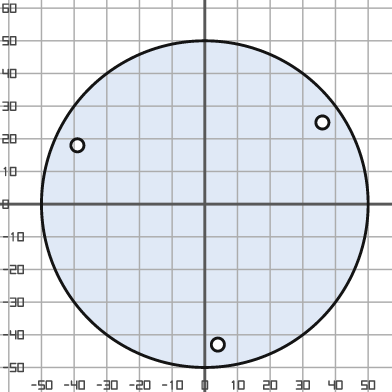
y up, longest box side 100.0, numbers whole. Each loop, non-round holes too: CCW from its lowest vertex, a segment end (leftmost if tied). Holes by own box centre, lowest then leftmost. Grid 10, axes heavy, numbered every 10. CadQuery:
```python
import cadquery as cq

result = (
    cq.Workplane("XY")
    .moveTo(0.0, 0.0)
    .circle(50.0)
    .moveTo(4.0, -43.0)
    .circle(2.0)
    .moveTo(-39.0, 18.0)
    .circle(2.0)
    .moveTo(36.0, 25.0)
    .circle(2.0)
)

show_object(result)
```